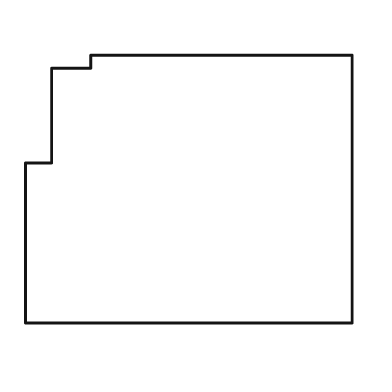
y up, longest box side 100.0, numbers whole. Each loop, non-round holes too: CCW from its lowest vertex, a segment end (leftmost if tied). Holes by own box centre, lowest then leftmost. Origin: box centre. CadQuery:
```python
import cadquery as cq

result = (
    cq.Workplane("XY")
    .moveTo(-50.0, -41.0)
    .lineTo(50.0, -41.0)
    .lineTo(50.0, 41.0)
    .lineTo(-30.0, 41.0)
    .lineTo(-30.0, 37.0)
    .lineTo(-42.0, 37.0)
    .lineTo(-42.0, 8.0)
    .lineTo(-50.0, 8.0)
    .close()
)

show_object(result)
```